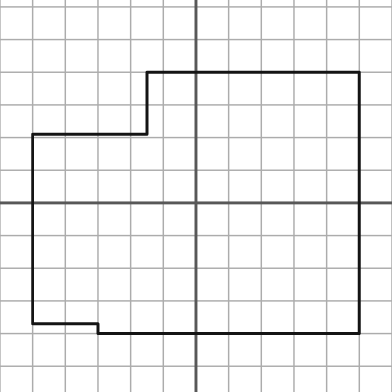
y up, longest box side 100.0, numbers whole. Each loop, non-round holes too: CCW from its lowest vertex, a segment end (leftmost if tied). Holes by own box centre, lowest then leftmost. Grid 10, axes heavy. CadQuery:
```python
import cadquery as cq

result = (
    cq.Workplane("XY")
    .moveTo(-30.0, -40.0)
    .lineTo(50.0, -40.0)
    .lineTo(50.0, 40.0)
    .lineTo(-15.0, 40.0)
    .lineTo(-15.0, 21.0)
    .lineTo(-50.0, 21.0)
    .lineTo(-50.0, -37.0)
    .lineTo(-30.0, -37.0)
    .close()
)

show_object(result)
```